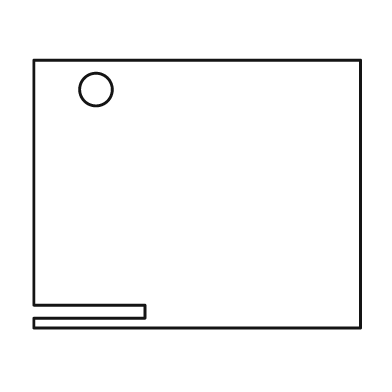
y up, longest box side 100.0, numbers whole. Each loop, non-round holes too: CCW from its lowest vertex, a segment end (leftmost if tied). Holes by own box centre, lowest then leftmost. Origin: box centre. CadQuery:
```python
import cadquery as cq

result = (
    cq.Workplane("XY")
    .moveTo(-50.0, -41.0)
    .lineTo(50.0, -41.0)
    .lineTo(50.0, 41.0)
    .lineTo(-50.0, 41.0)
    .lineTo(-50.0, -34.0)
    .lineTo(-16.0, -34.0)
    .lineTo(-16.0, -38.0)
    .lineTo(-50.0, -38.0)
    .close()
    .moveTo(-31.0, 32.0)
    .circle(5.0)
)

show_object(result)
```